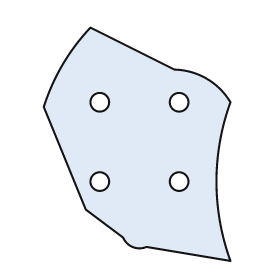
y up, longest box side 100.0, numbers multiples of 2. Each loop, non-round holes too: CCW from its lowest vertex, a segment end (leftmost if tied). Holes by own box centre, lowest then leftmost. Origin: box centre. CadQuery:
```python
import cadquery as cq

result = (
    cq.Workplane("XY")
    .moveTo(40.0, -50.0)
    .threePointArc((34.0, -16.0), (40.0, 18.0))
    .threePointArc((30.0, 28.0), (16.0, 32.0))
    .lineTo(-20.0, 50.0)
    .threePointArc((-32.0, 34.0), (-40.0, 16.0))
    .lineTo(-22.0, -28.0)
    .lineTo(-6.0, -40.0)
    .threePointArc((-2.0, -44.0), (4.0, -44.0))
    .close()
    .moveTo(-16.0, -16.0)
    .circle(4.0)
    .moveTo(18.0, -16.0)
    .circle(4.0)
    .moveTo(-16.0, 18.0)
    .circle(4.0)
    .moveTo(18.0, 18.0)
    .circle(4.0)
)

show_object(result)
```